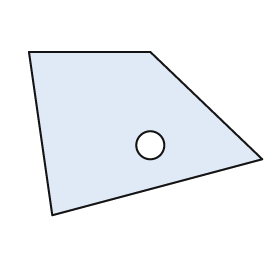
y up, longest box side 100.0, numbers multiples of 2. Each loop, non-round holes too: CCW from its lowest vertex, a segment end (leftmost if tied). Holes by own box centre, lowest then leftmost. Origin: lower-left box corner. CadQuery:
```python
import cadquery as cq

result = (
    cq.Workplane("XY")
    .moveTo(10.0, 0.0)
    .lineTo(100.0, 24.0)
    .lineTo(52.0, 70.0)
    .lineTo(0.0, 70.0)
    .close()
    .moveTo(52.0, 30.0)
    .circle(6.0)
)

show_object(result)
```